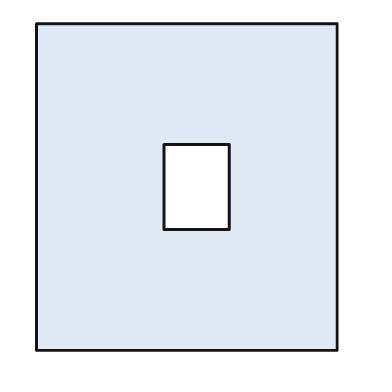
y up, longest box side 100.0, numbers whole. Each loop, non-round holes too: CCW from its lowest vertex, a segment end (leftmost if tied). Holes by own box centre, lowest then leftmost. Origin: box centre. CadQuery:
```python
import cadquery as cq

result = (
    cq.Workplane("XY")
    .moveTo(-46.0, -50.0)
    .lineTo(46.0, -50.0)
    .lineTo(46.0, 50.0)
    .lineTo(-46.0, 50.0)
    .close()
    .moveTo(-7.0, -13.0)
    .lineTo(13.0, -13.0)
    .lineTo(13.0, 13.0)
    .lineTo(-7.0, 13.0)
    .close()
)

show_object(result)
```